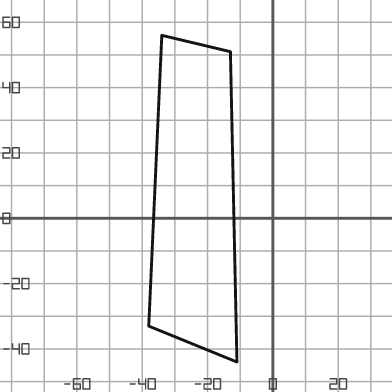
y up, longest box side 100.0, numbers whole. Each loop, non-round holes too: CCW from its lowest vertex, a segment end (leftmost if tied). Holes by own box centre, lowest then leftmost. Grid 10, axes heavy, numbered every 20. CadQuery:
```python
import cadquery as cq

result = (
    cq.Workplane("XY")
    .moveTo(-11.0, -44.0)
    .lineTo(-13.0, 51.0)
    .lineTo(-34.0, 56.0)
    .lineTo(-38.0, -33.0)
    .close()
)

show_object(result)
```